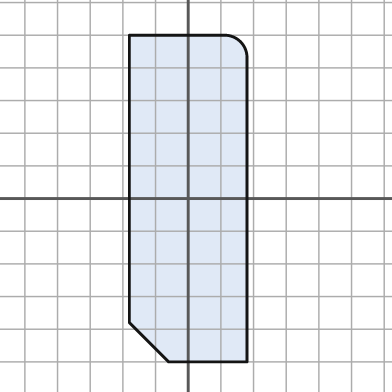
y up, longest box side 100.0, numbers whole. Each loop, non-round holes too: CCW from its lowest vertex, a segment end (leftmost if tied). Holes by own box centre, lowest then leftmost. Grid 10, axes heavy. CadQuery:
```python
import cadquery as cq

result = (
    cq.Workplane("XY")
    .moveTo(-6.0, -50.0)
    .lineTo(18.0, -50.0)
    .lineTo(18.0, 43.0)
    .threePointArc((16.0, 48.0), (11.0, 50.0))
    .lineTo(-18.0, 50.0)
    .lineTo(-18.0, -38.0)
    .close()
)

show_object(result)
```